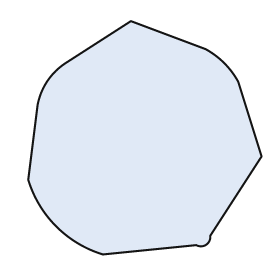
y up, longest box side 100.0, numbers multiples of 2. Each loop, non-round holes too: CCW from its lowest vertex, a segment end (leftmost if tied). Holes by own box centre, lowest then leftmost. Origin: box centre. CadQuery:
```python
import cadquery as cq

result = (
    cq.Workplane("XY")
    .moveTo(-18.0, -50.0)
    .lineTo(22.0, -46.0)
    .threePointArc((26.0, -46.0), (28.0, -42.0))
    .lineTo(50.0, -8.0)
    .lineTo(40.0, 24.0)
    .threePointArc((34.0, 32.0), (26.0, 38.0))
    .lineTo(-6.0, 50.0)
    .lineTo(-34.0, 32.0)
    .threePointArc((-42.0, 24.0), (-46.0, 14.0))
    .lineTo(-50.0, -18.0)
    .threePointArc((-38.0, -38.0), (-18.0, -50.0))
    .close()
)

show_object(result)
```